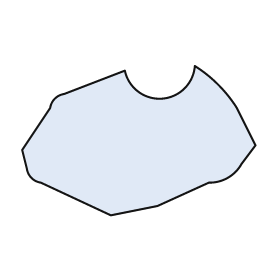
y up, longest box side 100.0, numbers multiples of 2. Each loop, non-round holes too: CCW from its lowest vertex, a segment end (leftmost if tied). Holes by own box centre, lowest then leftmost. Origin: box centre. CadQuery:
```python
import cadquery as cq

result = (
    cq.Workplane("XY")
    .moveTo(-12.0, -32.0)
    .lineTo(8.0, -28.0)
    .lineTo(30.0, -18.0)
    .threePointArc((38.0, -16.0), (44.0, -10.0))
    .lineTo(50.0, -2.0)
    .lineTo(42.0, 14.0)
    .threePointArc((34.0, 24.0), (24.0, 32.0))
    .threePointArc((10.0, 18.0), (-6.0, 30.0))
    .lineTo(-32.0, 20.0)
    .threePointArc((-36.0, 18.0), (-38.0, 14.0))
    .lineTo(-50.0, -4.0)
    .lineTo(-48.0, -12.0)
    .threePointArc((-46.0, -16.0), (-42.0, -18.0))
    .close()
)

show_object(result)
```